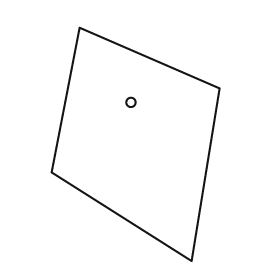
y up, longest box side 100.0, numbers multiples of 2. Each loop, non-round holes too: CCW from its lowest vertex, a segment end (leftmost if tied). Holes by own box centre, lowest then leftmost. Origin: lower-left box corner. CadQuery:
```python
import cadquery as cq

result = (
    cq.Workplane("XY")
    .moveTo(60.0, 0.0)
    .lineTo(72.0, 74.0)
    .lineTo(12.0, 100.0)
    .lineTo(0.0, 38.0)
    .close()
    .moveTo(34.0, 68.0)
    .circle(2.0)
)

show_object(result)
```